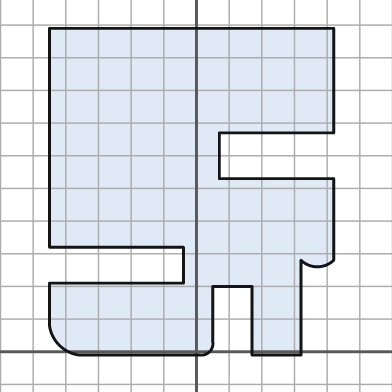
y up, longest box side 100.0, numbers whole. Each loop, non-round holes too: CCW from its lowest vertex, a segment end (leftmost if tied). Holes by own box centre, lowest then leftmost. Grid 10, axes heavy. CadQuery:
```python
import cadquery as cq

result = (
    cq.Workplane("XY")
    .moveTo(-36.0, -1.0)
    .lineTo(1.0, -1.0)
    .threePointArc((4.0, 0.0), (5.0, 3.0))
    .lineTo(5.0, 20.0)
    .lineTo(17.0, 20.0)
    .lineTo(17.0, -1.0)
    .lineTo(32.0, -1.0)
    .lineTo(32.0, 28.0)
    .threePointArc((37.0, 26.0), (42.0, 28.0))
    .lineTo(42.0, 53.0)
    .lineTo(7.0, 53.0)
    .lineTo(7.0, 67.0)
    .lineTo(42.0, 67.0)
    .lineTo(42.0, 99.0)
    .lineTo(-45.0, 99.0)
    .lineTo(-45.0, 32.0)
    .lineTo(-4.0, 32.0)
    .lineTo(-4.0, 21.0)
    .lineTo(-45.0, 21.0)
    .lineTo(-45.0, 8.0)
    .threePointArc((-42.0, 2.0), (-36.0, -1.0))
    .close()
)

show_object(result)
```